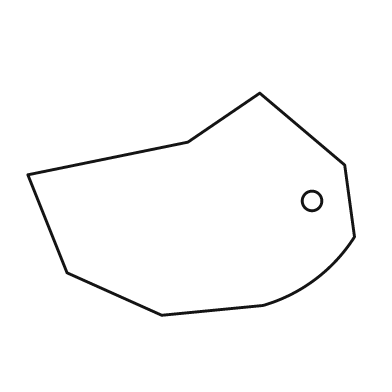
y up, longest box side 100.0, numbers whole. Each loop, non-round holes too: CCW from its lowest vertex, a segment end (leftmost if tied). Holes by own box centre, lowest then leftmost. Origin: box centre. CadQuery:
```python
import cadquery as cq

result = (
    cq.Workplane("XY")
    .moveTo(-9.0, -34.0)
    .lineTo(22.0, -31.0)
    .threePointArc((38.0, -23.0), (50.0, -10.0))
    .lineTo(47.0, 12.0)
    .lineTo(21.0, 34.0)
    .lineTo(-1.0, 19.0)
    .lineTo(-50.0, 9.0)
    .lineTo(-38.0, -21.0)
    .close()
    .moveTo(37.0, 1.0)
    .circle(3.0)
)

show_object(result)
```